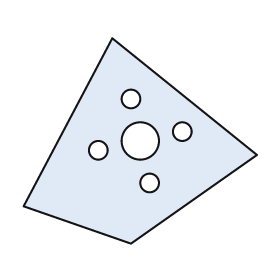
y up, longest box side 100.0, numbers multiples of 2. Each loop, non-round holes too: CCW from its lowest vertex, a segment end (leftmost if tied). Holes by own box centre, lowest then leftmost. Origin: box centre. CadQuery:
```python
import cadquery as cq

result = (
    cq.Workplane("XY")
    .moveTo(-4.0, -44.0)
    .lineTo(50.0, -6.0)
    .lineTo(-12.0, 44.0)
    .lineTo(-50.0, -28.0)
    .close()
    .moveTo(4.0, -18.0)
    .circle(4.0)
    .moveTo(-18.0, -4.0)
    .circle(4.0)
    .moveTo(0.0, 0.0)
    .circle(8.0)
    .moveTo(18.0, 4.0)
    .circle(4.0)
    .moveTo(-4.0, 18.0)
    .circle(4.0)
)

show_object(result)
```